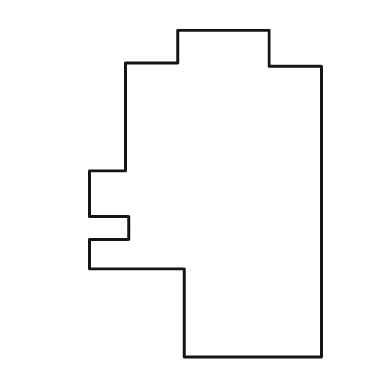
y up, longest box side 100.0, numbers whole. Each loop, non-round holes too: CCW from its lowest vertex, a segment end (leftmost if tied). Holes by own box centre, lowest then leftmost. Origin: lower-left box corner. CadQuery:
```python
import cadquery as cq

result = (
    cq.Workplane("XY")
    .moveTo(29.0, 0.0)
    .lineTo(71.0, 0.0)
    .lineTo(71.0, 89.0)
    .lineTo(55.0, 89.0)
    .lineTo(55.0, 100.0)
    .lineTo(27.0, 100.0)
    .lineTo(27.0, 90.0)
    .lineTo(11.0, 90.0)
    .lineTo(11.0, 57.0)
    .lineTo(0.0, 57.0)
    .lineTo(0.0, 43.0)
    .lineTo(12.0, 43.0)
    .lineTo(12.0, 36.0)
    .lineTo(0.0, 36.0)
    .lineTo(0.0, 27.0)
    .lineTo(29.0, 27.0)
    .close()
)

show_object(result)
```